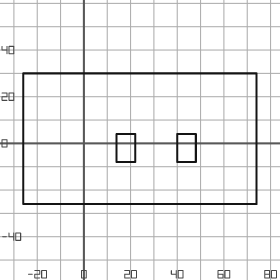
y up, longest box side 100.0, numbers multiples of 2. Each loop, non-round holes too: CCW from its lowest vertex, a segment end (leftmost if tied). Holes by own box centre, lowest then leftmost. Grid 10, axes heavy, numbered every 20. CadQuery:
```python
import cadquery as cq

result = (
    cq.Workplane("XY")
    .moveTo(-26.0, -26.0)
    .lineTo(74.0, -26.0)
    .lineTo(74.0, 30.0)
    .lineTo(-26.0, 30.0)
    .close()
    .moveTo(14.0, -8.0)
    .lineTo(22.0, -8.0)
    .lineTo(22.0, 4.0)
    .lineTo(14.0, 4.0)
    .close()
    .moveTo(40.0, -8.0)
    .lineTo(48.0, -8.0)
    .lineTo(48.0, 4.0)
    .lineTo(40.0, 4.0)
    .close()
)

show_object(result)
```